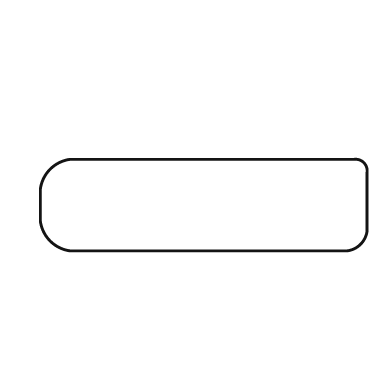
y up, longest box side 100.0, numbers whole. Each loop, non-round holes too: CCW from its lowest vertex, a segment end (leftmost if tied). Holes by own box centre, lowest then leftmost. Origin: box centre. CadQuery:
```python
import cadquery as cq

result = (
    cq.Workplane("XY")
    .moveTo(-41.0, -14.0)
    .lineTo(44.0, -14.0)
    .threePointArc((48.0, -12.0), (50.0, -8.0))
    .lineTo(50.0, 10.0)
    .threePointArc((49.0, 13.0), (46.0, 14.0))
    .lineTo(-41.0, 14.0)
    .threePointArc((-47.0, 11.0), (-50.0, 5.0))
    .lineTo(-50.0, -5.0)
    .threePointArc((-47.0, -11.0), (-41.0, -14.0))
    .close()
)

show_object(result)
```